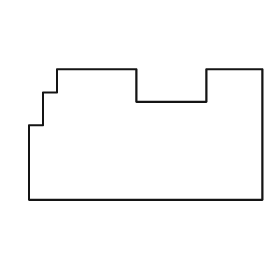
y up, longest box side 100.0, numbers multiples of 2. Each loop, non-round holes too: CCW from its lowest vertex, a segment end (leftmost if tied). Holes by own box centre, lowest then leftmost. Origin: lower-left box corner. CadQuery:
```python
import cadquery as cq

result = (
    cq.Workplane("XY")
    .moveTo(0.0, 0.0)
    .lineTo(100.0, 0.0)
    .lineTo(100.0, 56.0)
    .lineTo(76.0, 56.0)
    .lineTo(76.0, 42.0)
    .lineTo(46.0, 42.0)
    .lineTo(46.0, 56.0)
    .lineTo(12.0, 56.0)
    .lineTo(12.0, 46.0)
    .lineTo(6.0, 46.0)
    .lineTo(6.0, 32.0)
    .lineTo(0.0, 32.0)
    .close()
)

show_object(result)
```